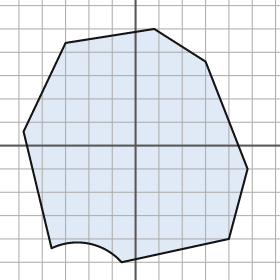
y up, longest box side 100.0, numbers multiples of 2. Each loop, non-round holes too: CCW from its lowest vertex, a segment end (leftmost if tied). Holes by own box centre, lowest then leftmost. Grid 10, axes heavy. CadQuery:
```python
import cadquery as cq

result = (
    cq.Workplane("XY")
    .moveTo(-6.0, -50.0)
    .lineTo(40.0, -40.0)
    .lineTo(48.0, -10.0)
    .lineTo(30.0, 36.0)
    .lineTo(8.0, 50.0)
    .lineTo(-30.0, 44.0)
    .lineTo(-48.0, 6.0)
    .lineTo(-36.0, -44.0)
    .threePointArc((-20.0, -42.0), (-6.0, -50.0))
    .close()
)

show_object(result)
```